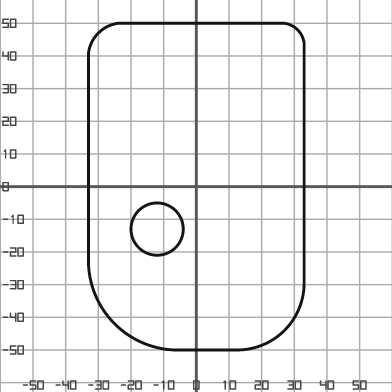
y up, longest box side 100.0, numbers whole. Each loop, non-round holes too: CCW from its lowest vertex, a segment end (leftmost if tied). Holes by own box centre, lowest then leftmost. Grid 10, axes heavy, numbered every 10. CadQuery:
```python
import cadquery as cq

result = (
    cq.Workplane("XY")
    .moveTo(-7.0, -50.0)
    .lineTo(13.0, -50.0)
    .threePointArc((27.0, -44.0), (33.0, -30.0))
    .lineTo(33.0, 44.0)
    .threePointArc((31.0, 48.0), (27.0, 50.0))
    .lineTo(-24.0, 50.0)
    .threePointArc((-30.0, 47.0), (-33.0, 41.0))
    .lineTo(-33.0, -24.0)
    .threePointArc((-25.0, -42.0), (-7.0, -50.0))
    .close()
    .moveTo(-12.0, -13.0)
    .circle(8.0)
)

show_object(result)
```